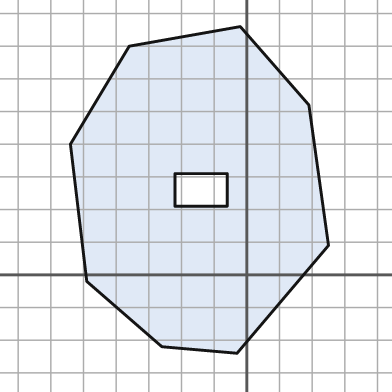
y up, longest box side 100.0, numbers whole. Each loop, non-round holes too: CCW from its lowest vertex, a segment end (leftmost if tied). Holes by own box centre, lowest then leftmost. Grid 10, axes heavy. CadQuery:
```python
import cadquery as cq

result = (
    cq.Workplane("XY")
    .moveTo(-3.0, -24.0)
    .lineTo(25.0, 9.0)
    .lineTo(19.0, 52.0)
    .lineTo(-2.0, 76.0)
    .lineTo(-36.0, 70.0)
    .lineTo(-54.0, 40.0)
    .lineTo(-49.0, -2.0)
    .lineTo(-26.0, -22.0)
    .close()
    .moveTo(-22.0, 21.0)
    .lineTo(-6.0, 21.0)
    .lineTo(-6.0, 31.0)
    .lineTo(-22.0, 31.0)
    .close()
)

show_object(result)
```